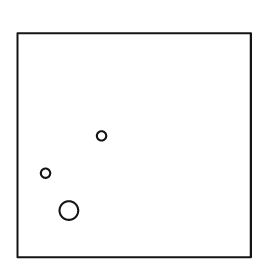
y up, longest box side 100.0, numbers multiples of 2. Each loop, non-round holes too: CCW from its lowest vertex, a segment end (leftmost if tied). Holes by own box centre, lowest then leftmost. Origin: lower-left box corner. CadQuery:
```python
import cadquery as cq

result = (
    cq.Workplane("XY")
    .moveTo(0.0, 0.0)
    .lineTo(100.0, 0.0)
    .lineTo(100.0, 96.0)
    .lineTo(0.0, 96.0)
    .close()
    .moveTo(22.0, 20.0)
    .circle(4.0)
    .moveTo(12.0, 36.0)
    .circle(2.0)
    .moveTo(36.0, 52.0)
    .circle(2.0)
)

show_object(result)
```